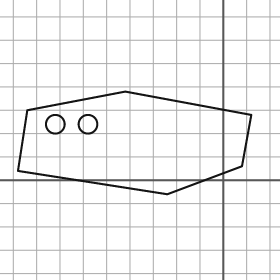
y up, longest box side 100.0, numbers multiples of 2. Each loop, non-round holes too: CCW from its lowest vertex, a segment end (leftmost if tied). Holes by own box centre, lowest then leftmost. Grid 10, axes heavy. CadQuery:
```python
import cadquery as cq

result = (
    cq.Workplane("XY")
    .moveTo(-24.0, -6.0)
    .lineTo(8.0, 6.0)
    .lineTo(12.0, 28.0)
    .lineTo(-42.0, 38.0)
    .lineTo(-84.0, 30.0)
    .lineTo(-88.0, 4.0)
    .close()
    .moveTo(-72.0, 24.0)
    .circle(4.0)
    .moveTo(-58.0, 24.0)
    .circle(4.0)
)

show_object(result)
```